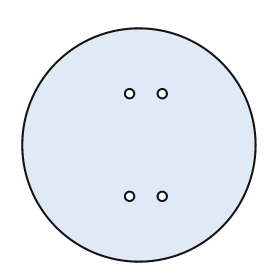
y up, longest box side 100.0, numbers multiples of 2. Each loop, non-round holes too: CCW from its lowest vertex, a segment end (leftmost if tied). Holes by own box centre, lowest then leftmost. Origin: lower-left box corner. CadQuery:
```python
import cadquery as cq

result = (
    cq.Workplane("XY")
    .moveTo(50.0, 50.0)
    .circle(50.0)
    .moveTo(46.0, 28.0)
    .circle(2.0)
    .moveTo(60.0, 28.0)
    .circle(2.0)
    .moveTo(46.0, 72.0)
    .circle(2.0)
    .moveTo(60.0, 72.0)
    .circle(2.0)
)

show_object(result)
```